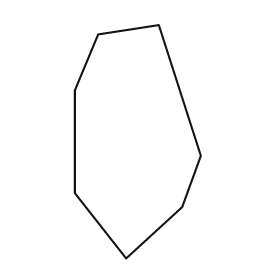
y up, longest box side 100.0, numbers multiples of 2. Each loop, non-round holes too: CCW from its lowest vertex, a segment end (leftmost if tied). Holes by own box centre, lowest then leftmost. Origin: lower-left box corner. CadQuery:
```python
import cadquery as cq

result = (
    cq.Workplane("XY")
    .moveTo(22.0, 0.0)
    .lineTo(46.0, 22.0)
    .lineTo(54.0, 44.0)
    .lineTo(36.0, 100.0)
    .lineTo(10.0, 96.0)
    .lineTo(0.0, 72.0)
    .lineTo(0.0, 28.0)
    .close()
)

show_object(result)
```